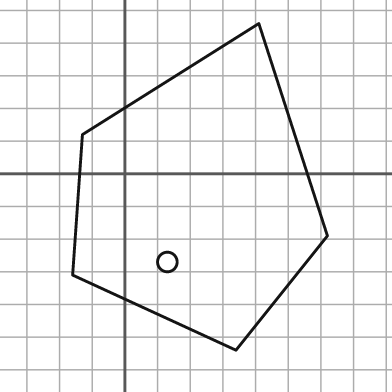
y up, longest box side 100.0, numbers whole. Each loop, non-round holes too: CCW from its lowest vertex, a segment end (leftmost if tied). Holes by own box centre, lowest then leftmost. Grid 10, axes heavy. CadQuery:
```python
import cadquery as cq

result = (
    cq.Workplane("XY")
    .moveTo(34.0, -54.0)
    .lineTo(62.0, -19.0)
    .lineTo(41.0, 46.0)
    .lineTo(-13.0, 12.0)
    .lineTo(-16.0, -31.0)
    .close()
    .moveTo(13.0, -27.0)
    .circle(3.0)
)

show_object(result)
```